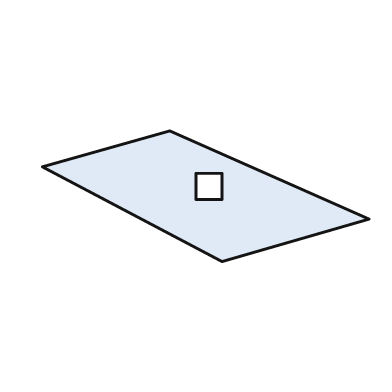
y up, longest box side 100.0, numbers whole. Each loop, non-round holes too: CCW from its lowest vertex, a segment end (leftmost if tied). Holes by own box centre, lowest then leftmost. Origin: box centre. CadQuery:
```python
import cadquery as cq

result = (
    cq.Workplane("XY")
    .moveTo(5.0, -20.0)
    .lineTo(50.0, -7.0)
    .lineTo(-11.0, 20.0)
    .lineTo(-50.0, 9.0)
    .close()
    .moveTo(-3.0, -1.0)
    .lineTo(5.0, -1.0)
    .lineTo(5.0, 7.0)
    .lineTo(-3.0, 7.0)
    .close()
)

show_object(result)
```